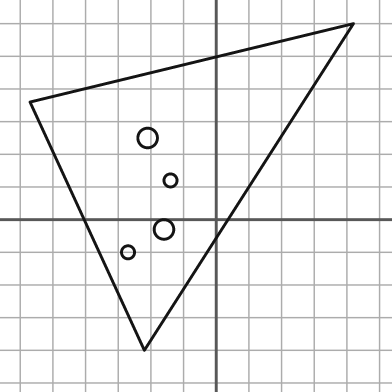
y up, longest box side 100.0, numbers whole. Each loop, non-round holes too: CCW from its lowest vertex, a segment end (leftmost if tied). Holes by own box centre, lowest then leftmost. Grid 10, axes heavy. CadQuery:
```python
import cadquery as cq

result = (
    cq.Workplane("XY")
    .moveTo(-22.0, -40.0)
    .lineTo(42.0, 60.0)
    .lineTo(-57.0, 36.0)
    .close()
    .moveTo(-27.0, -10.0)
    .circle(2.0)
    .moveTo(-16.0, -3.0)
    .circle(3.0)
    .moveTo(-14.0, 12.0)
    .circle(2.0)
    .moveTo(-21.0, 25.0)
    .circle(3.0)
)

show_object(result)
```